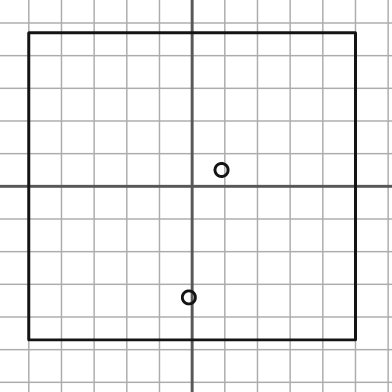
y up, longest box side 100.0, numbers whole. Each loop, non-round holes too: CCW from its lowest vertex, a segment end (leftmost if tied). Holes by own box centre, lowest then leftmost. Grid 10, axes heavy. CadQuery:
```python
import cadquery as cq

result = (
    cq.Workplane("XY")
    .moveTo(-50.0, -47.0)
    .lineTo(50.0, -47.0)
    .lineTo(50.0, 47.0)
    .lineTo(-50.0, 47.0)
    .close()
    .moveTo(-1.0, -34.0)
    .circle(2.0)
    .moveTo(9.0, 5.0)
    .circle(2.0)
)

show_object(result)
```